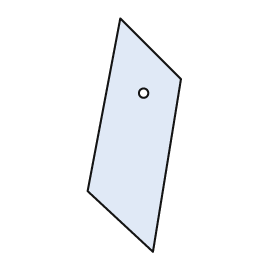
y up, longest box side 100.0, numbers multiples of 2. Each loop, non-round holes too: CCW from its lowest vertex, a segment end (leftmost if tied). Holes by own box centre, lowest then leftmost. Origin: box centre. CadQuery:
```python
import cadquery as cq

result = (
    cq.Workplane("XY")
    .moveTo(8.0, -50.0)
    .lineTo(20.0, 24.0)
    .lineTo(-6.0, 50.0)
    .lineTo(-20.0, -24.0)
    .close()
    .moveTo(4.0, 18.0)
    .circle(2.0)
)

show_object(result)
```